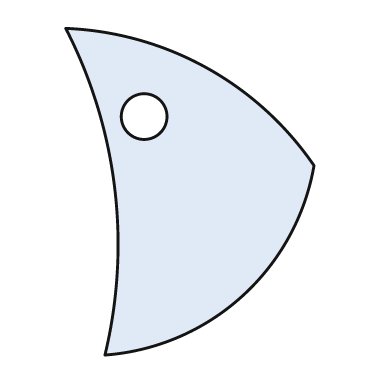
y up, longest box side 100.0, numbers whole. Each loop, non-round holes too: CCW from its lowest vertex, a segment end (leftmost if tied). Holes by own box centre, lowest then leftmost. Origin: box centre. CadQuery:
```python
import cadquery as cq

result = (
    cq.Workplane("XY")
    .moveTo(-26.0, -50.0)
    .threePointArc((16.0, -32.0), (38.0, 8.0))
    .threePointArc((5.0, 38.0), (-38.0, 50.0))
    .threePointArc((-23.0, 1.0), (-26.0, -50.0))
    .close()
    .moveTo(-14.0, 23.0)
    .circle(7.0)
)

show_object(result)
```